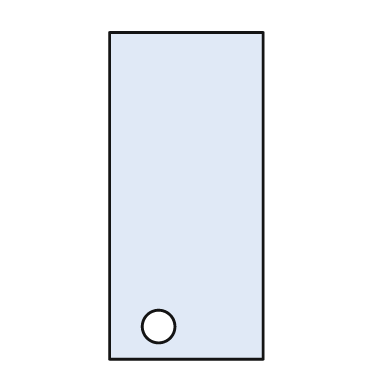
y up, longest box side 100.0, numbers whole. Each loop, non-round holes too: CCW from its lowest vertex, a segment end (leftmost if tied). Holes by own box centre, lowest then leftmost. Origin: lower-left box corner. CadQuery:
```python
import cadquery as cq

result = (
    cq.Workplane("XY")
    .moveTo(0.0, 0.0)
    .lineTo(47.0, 0.0)
    .lineTo(47.0, 100.0)
    .lineTo(0.0, 100.0)
    .close()
    .moveTo(15.0, 10.0)
    .circle(5.0)
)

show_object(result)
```